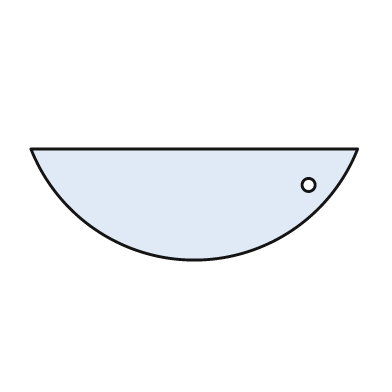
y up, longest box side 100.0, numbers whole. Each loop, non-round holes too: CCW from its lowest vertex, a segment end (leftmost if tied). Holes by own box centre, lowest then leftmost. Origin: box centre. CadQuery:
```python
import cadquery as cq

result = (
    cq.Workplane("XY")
    .moveTo(-50.0, 17.0)
    .threePointArc((0.0, -17.0), (50.0, 17.0))
    .close()
    .moveTo(35.0, 6.0)
    .circle(2.0)
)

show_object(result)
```